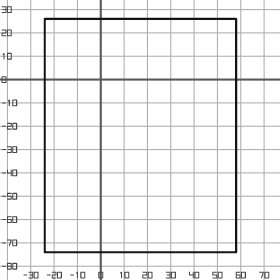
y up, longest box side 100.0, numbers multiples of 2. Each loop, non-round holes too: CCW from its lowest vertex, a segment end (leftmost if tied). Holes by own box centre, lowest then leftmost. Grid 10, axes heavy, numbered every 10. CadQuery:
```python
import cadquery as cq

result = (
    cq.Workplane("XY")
    .moveTo(-24.0, -74.0)
    .lineTo(58.0, -74.0)
    .lineTo(58.0, 26.0)
    .lineTo(-24.0, 26.0)
    .close()
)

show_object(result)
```